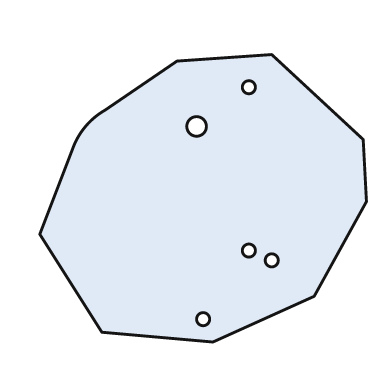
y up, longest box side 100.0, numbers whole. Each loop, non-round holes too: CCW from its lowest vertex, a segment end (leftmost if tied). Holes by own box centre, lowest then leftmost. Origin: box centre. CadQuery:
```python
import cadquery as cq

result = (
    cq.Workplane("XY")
    .moveTo(3.0, -44.0)
    .lineTo(34.0, -30.0)
    .lineTo(50.0, -1.0)
    .lineTo(49.0, 18.0)
    .lineTo(21.0, 44.0)
    .lineTo(-8.0, 42.0)
    .lineTo(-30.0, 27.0)
    .threePointArc((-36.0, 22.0), (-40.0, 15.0))
    .lineTo(-50.0, -11.0)
    .lineTo(-31.0, -41.0)
    .close()
    .moveTo(0.0, -37.0)
    .circle(2.0)
    .moveTo(21.0, -19.0)
    .circle(2.0)
    .moveTo(14.0, -16.0)
    .circle(2.0)
    .moveTo(-2.0, 22.0)
    .circle(3.0)
    .moveTo(14.0, 34.0)
    .circle(2.0)
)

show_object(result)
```